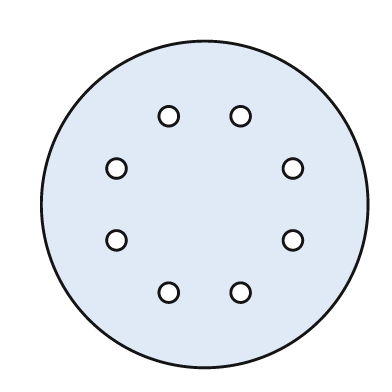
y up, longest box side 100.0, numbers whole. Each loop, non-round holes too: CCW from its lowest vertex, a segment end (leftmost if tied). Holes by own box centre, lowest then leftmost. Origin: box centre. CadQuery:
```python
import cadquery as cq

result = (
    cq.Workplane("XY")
    .moveTo(0.0, 0.0)
    .circle(50.0)
    .moveTo(-11.0, -27.0)
    .circle(3.0)
    .moveTo(11.0, -27.0)
    .circle(3.0)
    .moveTo(-27.0, -11.0)
    .circle(3.0)
    .moveTo(27.0, -11.0)
    .circle(3.0)
    .moveTo(-27.0, 11.0)
    .circle(3.0)
    .moveTo(27.0, 11.0)
    .circle(3.0)
    .moveTo(-11.0, 27.0)
    .circle(3.0)
    .moveTo(11.0, 27.0)
    .circle(3.0)
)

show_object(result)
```